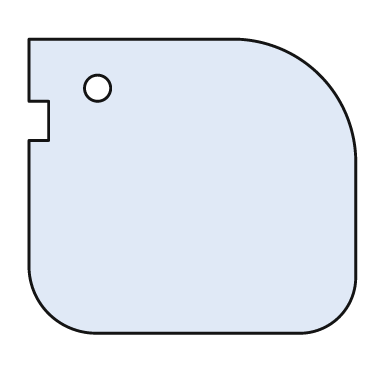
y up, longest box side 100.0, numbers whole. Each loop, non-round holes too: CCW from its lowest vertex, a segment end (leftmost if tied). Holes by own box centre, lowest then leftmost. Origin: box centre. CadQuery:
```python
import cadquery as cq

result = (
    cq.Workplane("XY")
    .moveTo(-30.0, -45.0)
    .lineTo(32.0, -45.0)
    .threePointArc((45.0, -40.0), (50.0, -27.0))
    .lineTo(50.0, 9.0)
    .threePointArc((39.0, 34.0), (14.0, 45.0))
    .lineTo(-50.0, 45.0)
    .lineTo(-50.0, 26.0)
    .lineTo(-44.0, 26.0)
    .lineTo(-44.0, 14.0)
    .lineTo(-50.0, 14.0)
    .lineTo(-50.0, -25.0)
    .threePointArc((-44.0, -39.0), (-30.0, -45.0))
    .close()
    .moveTo(-29.0, 30.0)
    .circle(4.0)
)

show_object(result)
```